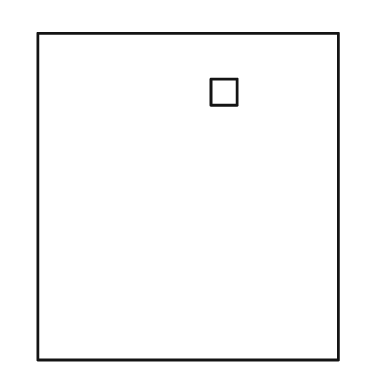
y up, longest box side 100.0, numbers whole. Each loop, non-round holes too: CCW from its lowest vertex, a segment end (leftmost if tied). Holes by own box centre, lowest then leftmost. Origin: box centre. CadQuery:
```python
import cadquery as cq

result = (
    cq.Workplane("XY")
    .moveTo(-46.0, -50.0)
    .lineTo(46.0, -50.0)
    .lineTo(46.0, 50.0)
    .lineTo(-46.0, 50.0)
    .close()
    .moveTo(7.0, 28.0)
    .lineTo(15.0, 28.0)
    .lineTo(15.0, 36.0)
    .lineTo(7.0, 36.0)
    .close()
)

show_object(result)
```